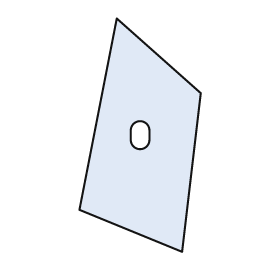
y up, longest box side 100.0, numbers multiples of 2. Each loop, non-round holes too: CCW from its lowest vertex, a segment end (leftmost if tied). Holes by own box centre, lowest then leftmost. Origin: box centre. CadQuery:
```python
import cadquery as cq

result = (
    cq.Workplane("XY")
    .moveTo(18.0, -50.0)
    .lineTo(26.0, 18.0)
    .lineTo(-10.0, 50.0)
    .lineTo(-26.0, -32.0)
    .close()
    .moveTo(-4.0, -2.0)
    .threePointArc((0.0, -6.0), (4.0, -2.0))
    .lineTo(4.0, 2.0)
    .threePointArc((0.0, 6.0), (-4.0, 2.0))
    .close()
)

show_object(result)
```